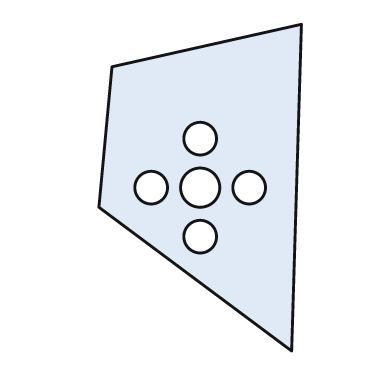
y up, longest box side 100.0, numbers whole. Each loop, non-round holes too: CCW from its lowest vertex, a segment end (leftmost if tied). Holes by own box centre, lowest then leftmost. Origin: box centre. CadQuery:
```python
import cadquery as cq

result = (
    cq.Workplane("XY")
    .moveTo(28.0, -50.0)
    .lineTo(31.0, 50.0)
    .lineTo(-27.0, 37.0)
    .lineTo(-31.0, -6.0)
    .close()
    .moveTo(0.0, -15.0)
    .circle(5.0)
    .moveTo(-15.0, 0.0)
    .circle(5.0)
    .moveTo(0.0, 0.0)
    .circle(6.0)
    .moveTo(15.0, 0.0)
    .circle(5.0)
    .moveTo(0.0, 15.0)
    .circle(5.0)
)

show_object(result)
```